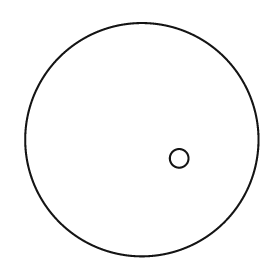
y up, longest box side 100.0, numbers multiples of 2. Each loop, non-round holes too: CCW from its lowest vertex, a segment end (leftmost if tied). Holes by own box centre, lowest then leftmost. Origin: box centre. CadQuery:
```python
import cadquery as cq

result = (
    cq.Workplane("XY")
    .moveTo(0.0, 0.0)
    .circle(50.0)
    .moveTo(16.0, -8.0)
    .circle(4.0)
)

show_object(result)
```